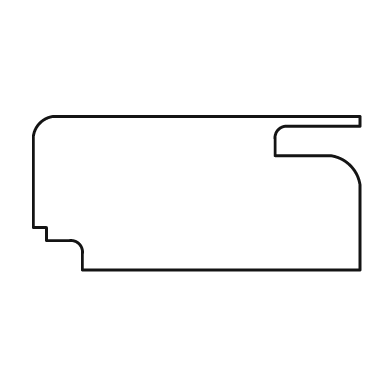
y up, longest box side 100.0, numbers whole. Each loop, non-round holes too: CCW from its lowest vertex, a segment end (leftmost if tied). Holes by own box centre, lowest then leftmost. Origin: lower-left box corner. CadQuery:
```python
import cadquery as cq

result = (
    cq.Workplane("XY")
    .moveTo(15.0, 0.0)
    .lineTo(100.0, 0.0)
    .lineTo(100.0, 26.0)
    .threePointArc((97.0, 32.0), (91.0, 35.0))
    .lineTo(74.0, 35.0)
    .lineTo(74.0, 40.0)
    .threePointArc((75.0, 43.0), (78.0, 44.0))
    .lineTo(100.0, 44.0)
    .lineTo(100.0, 47.0)
    .lineTo(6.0, 47.0)
    .threePointArc((2.0, 45.0), (0.0, 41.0))
    .lineTo(0.0, 13.0)
    .lineTo(4.0, 13.0)
    .lineTo(4.0, 9.0)
    .lineTo(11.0, 9.0)
    .threePointArc((14.0, 8.0), (15.0, 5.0))
    .close()
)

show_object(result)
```